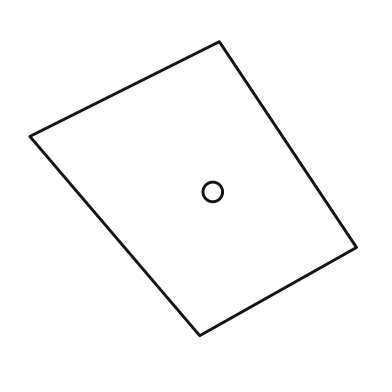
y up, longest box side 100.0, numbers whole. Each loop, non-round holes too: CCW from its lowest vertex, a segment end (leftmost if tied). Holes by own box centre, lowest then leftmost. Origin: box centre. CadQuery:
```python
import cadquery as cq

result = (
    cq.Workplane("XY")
    .moveTo(2.0, -45.0)
    .lineTo(50.0, -18.0)
    .lineTo(8.0, 45.0)
    .lineTo(-50.0, 16.0)
    .close()
    .moveTo(6.0, -1.0)
    .circle(3.0)
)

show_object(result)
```